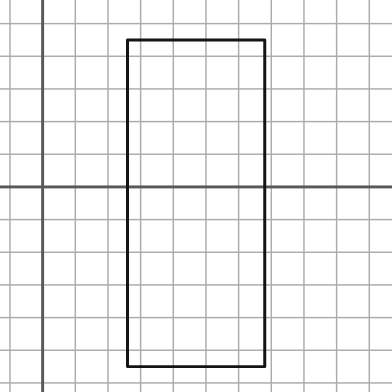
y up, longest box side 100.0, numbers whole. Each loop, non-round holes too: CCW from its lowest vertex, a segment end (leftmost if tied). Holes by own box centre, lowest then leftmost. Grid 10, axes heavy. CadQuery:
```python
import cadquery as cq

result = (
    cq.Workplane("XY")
    .moveTo(26.0, -55.0)
    .lineTo(68.0, -55.0)
    .lineTo(68.0, 45.0)
    .lineTo(26.0, 45.0)
    .close()
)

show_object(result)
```